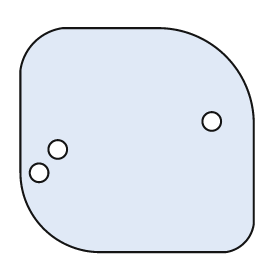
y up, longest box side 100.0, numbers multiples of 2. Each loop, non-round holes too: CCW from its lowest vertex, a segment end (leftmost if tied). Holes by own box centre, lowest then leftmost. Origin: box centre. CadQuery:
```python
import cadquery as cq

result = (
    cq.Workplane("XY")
    .moveTo(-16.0, -48.0)
    .lineTo(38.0, -48.0)
    .threePointArc((46.0, -44.0), (50.0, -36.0))
    .lineTo(50.0, 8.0)
    .threePointArc((38.0, 36.0), (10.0, 48.0))
    .lineTo(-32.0, 48.0)
    .threePointArc((-44.0, 42.0), (-50.0, 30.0))
    .lineTo(-50.0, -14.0)
    .threePointArc((-40.0, -38.0), (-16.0, -48.0))
    .close()
    .moveTo(-42.0, -14.0)
    .circle(4.0)
    .moveTo(-34.0, -4.0)
    .circle(4.0)
    .moveTo(32.0, 8.0)
    .circle(4.0)
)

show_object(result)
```